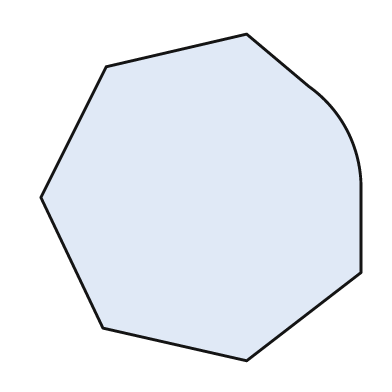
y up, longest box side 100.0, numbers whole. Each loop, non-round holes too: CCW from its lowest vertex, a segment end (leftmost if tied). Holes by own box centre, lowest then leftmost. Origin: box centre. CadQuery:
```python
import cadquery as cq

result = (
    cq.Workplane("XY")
    .moveTo(14.0, -50.0)
    .lineTo(49.0, -23.0)
    .lineTo(49.0, 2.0)
    .threePointArc((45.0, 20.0), (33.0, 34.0))
    .lineTo(14.0, 50.0)
    .lineTo(-29.0, 40.0)
    .lineTo(-49.0, 0.0)
    .lineTo(-30.0, -40.0)
    .close()
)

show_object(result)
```